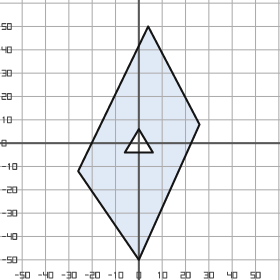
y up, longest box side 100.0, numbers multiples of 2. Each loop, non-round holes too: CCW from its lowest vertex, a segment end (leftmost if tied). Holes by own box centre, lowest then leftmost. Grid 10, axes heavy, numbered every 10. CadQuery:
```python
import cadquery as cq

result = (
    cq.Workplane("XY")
    .moveTo(0.0, -50.0)
    .lineTo(26.0, 8.0)
    .lineTo(4.0, 50.0)
    .lineTo(-26.0, -12.0)
    .close()
    .moveTo(-6.0, -4.0)
    .lineTo(6.0, -4.0)
    .lineTo(0.0, 6.0)
    .close()
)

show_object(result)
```